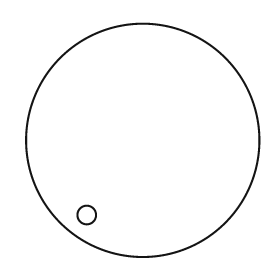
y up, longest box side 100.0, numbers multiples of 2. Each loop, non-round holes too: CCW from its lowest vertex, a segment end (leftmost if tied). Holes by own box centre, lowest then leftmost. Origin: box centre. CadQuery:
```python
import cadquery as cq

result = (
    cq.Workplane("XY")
    .moveTo(0.0, 0.0)
    .circle(50.0)
    .moveTo(-24.0, -32.0)
    .circle(4.0)
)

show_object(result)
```